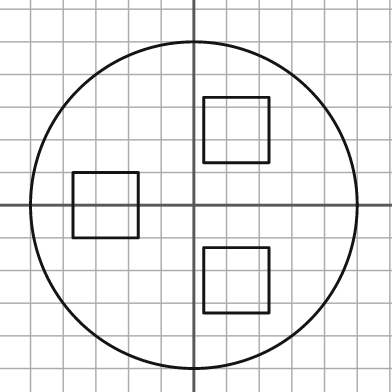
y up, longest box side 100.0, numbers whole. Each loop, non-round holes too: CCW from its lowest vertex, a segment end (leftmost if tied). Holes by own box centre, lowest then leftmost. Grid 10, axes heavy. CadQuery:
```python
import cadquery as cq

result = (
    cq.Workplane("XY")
    .moveTo(0.0, 0.0)
    .circle(50.0)
    .moveTo(3.0, -33.0)
    .lineTo(23.0, -33.0)
    .lineTo(23.0, -13.0)
    .lineTo(3.0, -13.0)
    .close()
    .moveTo(-37.0, -10.0)
    .lineTo(-17.0, -10.0)
    .lineTo(-17.0, 10.0)
    .lineTo(-37.0, 10.0)
    .close()
    .moveTo(3.0, 13.0)
    .lineTo(23.0, 13.0)
    .lineTo(23.0, 33.0)
    .lineTo(3.0, 33.0)
    .close()
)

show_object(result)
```